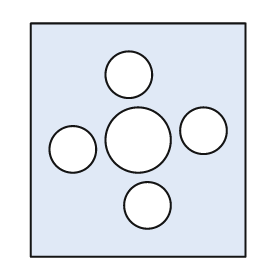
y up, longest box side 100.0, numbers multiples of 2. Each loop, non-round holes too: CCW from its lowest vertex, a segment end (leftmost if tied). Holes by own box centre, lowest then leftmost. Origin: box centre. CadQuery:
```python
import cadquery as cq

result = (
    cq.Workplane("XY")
    .moveTo(-46.0, -50.0)
    .lineTo(46.0, -50.0)
    .lineTo(46.0, 50.0)
    .lineTo(-46.0, 50.0)
    .close()
    .moveTo(4.0, -28.0)
    .circle(10.0)
    .moveTo(-28.0, -4.0)
    .circle(10.0)
    .moveTo(0.0, 0.0)
    .circle(14.0)
    .moveTo(28.0, 4.0)
    .circle(10.0)
    .moveTo(-4.0, 28.0)
    .circle(10.0)
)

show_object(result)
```